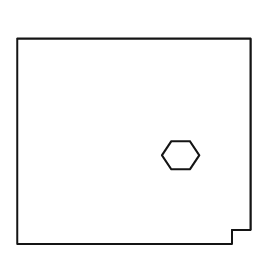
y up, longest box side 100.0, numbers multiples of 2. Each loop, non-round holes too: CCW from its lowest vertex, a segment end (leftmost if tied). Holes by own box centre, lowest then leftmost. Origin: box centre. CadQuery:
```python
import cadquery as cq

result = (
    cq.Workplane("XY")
    .moveTo(-50.0, -44.0)
    .lineTo(42.0, -44.0)
    .lineTo(42.0, -38.0)
    .lineTo(50.0, -38.0)
    .lineTo(50.0, 44.0)
    .lineTo(-50.0, 44.0)
    .close()
    .moveTo(16.0, -12.0)
    .lineTo(24.0, -12.0)
    .lineTo(28.0, -6.0)
    .lineTo(24.0, 0.0)
    .lineTo(16.0, 0.0)
    .lineTo(12.0, -6.0)
    .close()
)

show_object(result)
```